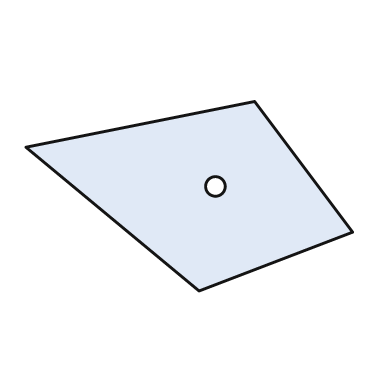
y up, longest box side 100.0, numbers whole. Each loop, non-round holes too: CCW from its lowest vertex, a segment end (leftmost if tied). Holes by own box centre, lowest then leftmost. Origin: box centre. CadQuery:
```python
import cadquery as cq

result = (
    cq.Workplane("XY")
    .moveTo(3.0, -29.0)
    .lineTo(50.0, -11.0)
    .lineTo(20.0, 29.0)
    .lineTo(-50.0, 15.0)
    .close()
    .moveTo(8.0, 3.0)
    .circle(3.0)
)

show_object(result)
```